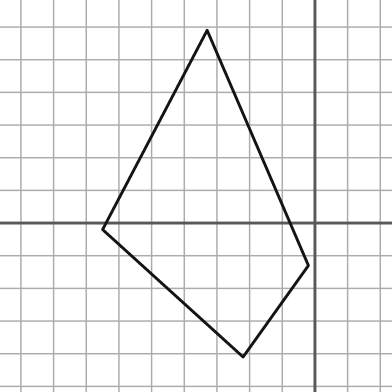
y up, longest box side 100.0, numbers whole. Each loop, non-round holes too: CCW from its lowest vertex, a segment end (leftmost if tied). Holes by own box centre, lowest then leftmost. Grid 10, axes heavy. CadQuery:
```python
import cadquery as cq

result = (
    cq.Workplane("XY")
    .moveTo(-22.0, -41.0)
    .lineTo(-2.0, -13.0)
    .lineTo(-33.0, 59.0)
    .lineTo(-65.0, -2.0)
    .close()
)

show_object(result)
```